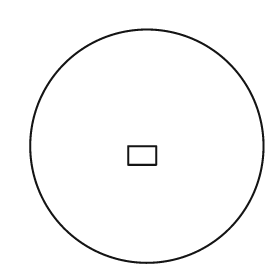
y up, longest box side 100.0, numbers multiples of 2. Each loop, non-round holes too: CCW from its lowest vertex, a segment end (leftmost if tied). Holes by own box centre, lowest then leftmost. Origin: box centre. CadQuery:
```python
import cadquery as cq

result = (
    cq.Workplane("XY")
    .moveTo(0.0, 0.0)
    .circle(50.0)
    .moveTo(-8.0, -8.0)
    .lineTo(4.0, -8.0)
    .lineTo(4.0, 0.0)
    .lineTo(-8.0, 0.0)
    .close()
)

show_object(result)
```